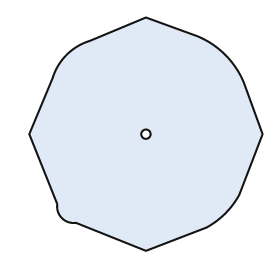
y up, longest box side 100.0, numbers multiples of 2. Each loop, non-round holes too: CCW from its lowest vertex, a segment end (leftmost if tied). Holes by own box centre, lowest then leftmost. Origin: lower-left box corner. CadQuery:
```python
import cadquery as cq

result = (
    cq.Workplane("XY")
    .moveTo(50.0, 0.0)
    .lineTo(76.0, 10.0)
    .threePointArc((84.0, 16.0), (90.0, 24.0))
    .lineTo(100.0, 50.0)
    .lineTo(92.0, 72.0)
    .threePointArc((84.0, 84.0), (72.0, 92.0))
    .lineTo(50.0, 100.0)
    .lineTo(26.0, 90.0)
    .threePointArc((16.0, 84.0), (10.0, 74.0))
    .lineTo(0.0, 50.0)
    .lineTo(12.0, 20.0)
    .threePointArc((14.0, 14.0), (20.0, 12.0))
    .close()
    .moveTo(50.0, 50.0)
    .circle(2.0)
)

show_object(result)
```